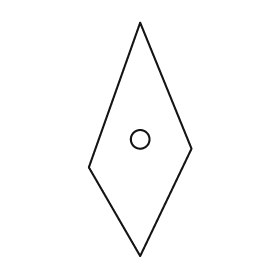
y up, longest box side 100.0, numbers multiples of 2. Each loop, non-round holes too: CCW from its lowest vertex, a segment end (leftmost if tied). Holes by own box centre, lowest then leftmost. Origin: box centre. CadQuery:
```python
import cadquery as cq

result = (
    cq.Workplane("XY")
    .moveTo(0.0, -50.0)
    .lineTo(22.0, -4.0)
    .lineTo(0.0, 50.0)
    .lineTo(-22.0, -12.0)
    .close()
    .moveTo(0.0, 0.0)
    .circle(4.0)
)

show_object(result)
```